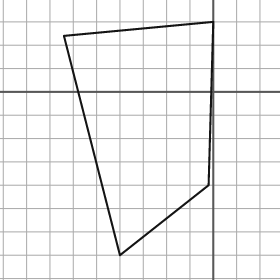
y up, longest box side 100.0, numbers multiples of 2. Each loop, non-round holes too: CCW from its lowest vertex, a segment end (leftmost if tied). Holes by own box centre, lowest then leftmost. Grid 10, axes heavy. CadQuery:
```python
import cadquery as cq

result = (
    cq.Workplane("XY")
    .moveTo(-40.0, -70.0)
    .lineTo(-2.0, -40.0)
    .lineTo(0.0, 30.0)
    .lineTo(-64.0, 24.0)
    .close()
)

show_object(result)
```